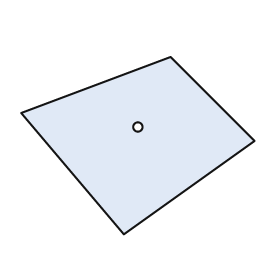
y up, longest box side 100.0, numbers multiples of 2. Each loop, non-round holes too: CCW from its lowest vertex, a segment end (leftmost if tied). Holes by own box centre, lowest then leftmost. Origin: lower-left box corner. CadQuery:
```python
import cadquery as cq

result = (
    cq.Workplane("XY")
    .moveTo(44.0, 0.0)
    .lineTo(100.0, 40.0)
    .lineTo(64.0, 76.0)
    .lineTo(0.0, 52.0)
    .close()
    .moveTo(50.0, 46.0)
    .circle(2.0)
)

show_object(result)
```